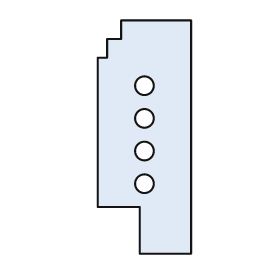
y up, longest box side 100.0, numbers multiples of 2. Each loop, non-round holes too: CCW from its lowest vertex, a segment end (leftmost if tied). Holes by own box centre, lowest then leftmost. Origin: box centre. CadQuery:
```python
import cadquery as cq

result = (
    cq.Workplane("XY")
    .moveTo(-2.0, -50.0)
    .lineTo(20.0, -50.0)
    .lineTo(20.0, 50.0)
    .lineTo(-10.0, 50.0)
    .lineTo(-10.0, 42.0)
    .lineTo(-16.0, 42.0)
    .lineTo(-16.0, 34.0)
    .lineTo(-20.0, 34.0)
    .lineTo(-20.0, -30.0)
    .lineTo(-2.0, -30.0)
    .close()
    .moveTo(0.0, -20.0)
    .circle(4.0)
    .moveTo(0.0, -6.0)
    .circle(4.0)
    .moveTo(0.0, 8.0)
    .circle(4.0)
    .moveTo(0.0, 22.0)
    .circle(4.0)
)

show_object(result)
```